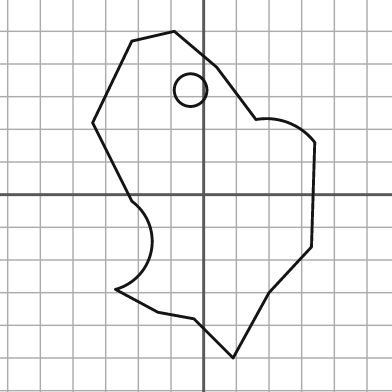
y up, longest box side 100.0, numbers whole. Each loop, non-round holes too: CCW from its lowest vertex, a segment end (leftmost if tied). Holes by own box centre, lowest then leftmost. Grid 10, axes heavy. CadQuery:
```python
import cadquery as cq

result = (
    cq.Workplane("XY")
    .moveTo(9.0, -50.0)
    .lineTo(20.0, -30.0)
    .lineTo(33.0, -16.0)
    .lineTo(34.0, 16.0)
    .threePointArc((26.0, 22.0), (16.0, 23.0))
    .lineTo(4.0, 39.0)
    .lineTo(-9.0, 50.0)
    .lineTo(-22.0, 47.0)
    .lineTo(-34.0, 22.0)
    .lineTo(-22.0, -2.0)
    .threePointArc((-16.0, -17.0), (-27.0, -29.0))
    .lineTo(-14.0, -36.0)
    .lineTo(-3.0, -38.0)
    .close()
    .moveTo(-4.0, 32.0)
    .circle(5.0)
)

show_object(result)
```